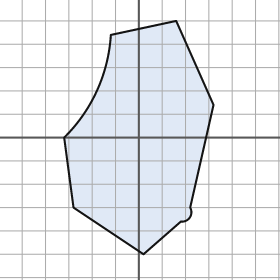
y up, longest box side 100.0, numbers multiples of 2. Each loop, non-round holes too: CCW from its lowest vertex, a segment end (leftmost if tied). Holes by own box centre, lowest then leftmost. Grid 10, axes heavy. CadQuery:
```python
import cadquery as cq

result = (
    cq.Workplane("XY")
    .moveTo(2.0, -50.0)
    .lineTo(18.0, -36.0)
    .threePointArc((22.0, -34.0), (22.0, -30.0))
    .lineTo(32.0, 14.0)
    .lineTo(16.0, 50.0)
    .lineTo(-12.0, 44.0)
    .threePointArc((-18.0, 20.0), (-32.0, 0.0))
    .lineTo(-28.0, -30.0)
    .close()
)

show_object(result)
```